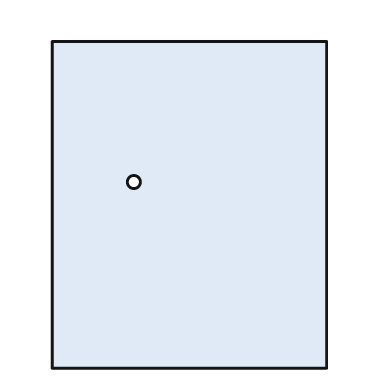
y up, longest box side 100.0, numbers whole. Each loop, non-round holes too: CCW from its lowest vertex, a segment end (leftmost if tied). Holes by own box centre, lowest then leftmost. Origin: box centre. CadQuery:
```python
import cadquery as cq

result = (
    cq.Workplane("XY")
    .moveTo(-42.0, -50.0)
    .lineTo(42.0, -50.0)
    .lineTo(42.0, 50.0)
    .lineTo(-42.0, 50.0)
    .close()
    .moveTo(-17.0, 7.0)
    .circle(2.0)
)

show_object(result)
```